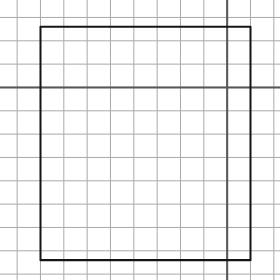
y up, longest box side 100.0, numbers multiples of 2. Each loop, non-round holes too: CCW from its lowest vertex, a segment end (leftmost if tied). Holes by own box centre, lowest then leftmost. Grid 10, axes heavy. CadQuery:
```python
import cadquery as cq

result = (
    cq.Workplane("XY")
    .moveTo(-80.0, -74.0)
    .lineTo(10.0, -74.0)
    .lineTo(10.0, 26.0)
    .lineTo(-80.0, 26.0)
    .close()
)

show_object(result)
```